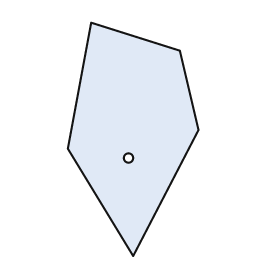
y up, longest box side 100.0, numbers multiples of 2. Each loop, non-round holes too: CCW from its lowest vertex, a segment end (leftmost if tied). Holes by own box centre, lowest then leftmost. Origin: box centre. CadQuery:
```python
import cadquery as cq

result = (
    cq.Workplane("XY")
    .moveTo(0.0, -50.0)
    .lineTo(28.0, 4.0)
    .lineTo(20.0, 38.0)
    .lineTo(-18.0, 50.0)
    .lineTo(-28.0, -4.0)
    .close()
    .moveTo(-2.0, -8.0)
    .circle(2.0)
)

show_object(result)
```